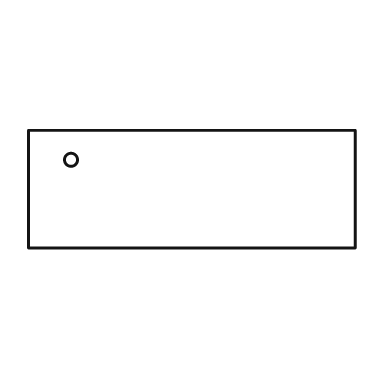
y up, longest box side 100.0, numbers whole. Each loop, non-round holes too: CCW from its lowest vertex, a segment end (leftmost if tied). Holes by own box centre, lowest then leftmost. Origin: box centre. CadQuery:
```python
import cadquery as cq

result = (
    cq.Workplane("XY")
    .moveTo(-50.0, -18.0)
    .lineTo(50.0, -18.0)
    .lineTo(50.0, 18.0)
    .lineTo(-50.0, 18.0)
    .close()
    .moveTo(-37.0, 9.0)
    .circle(2.0)
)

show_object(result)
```